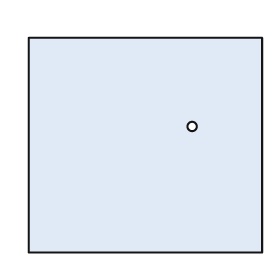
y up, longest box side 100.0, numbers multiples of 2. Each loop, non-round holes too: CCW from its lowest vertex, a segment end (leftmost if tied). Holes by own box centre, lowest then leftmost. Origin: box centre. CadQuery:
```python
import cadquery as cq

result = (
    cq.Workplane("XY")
    .moveTo(-50.0, -46.0)
    .lineTo(50.0, -46.0)
    .lineTo(50.0, 46.0)
    .lineTo(-50.0, 46.0)
    .close()
    .moveTo(20.0, 8.0)
    .circle(2.0)
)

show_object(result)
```